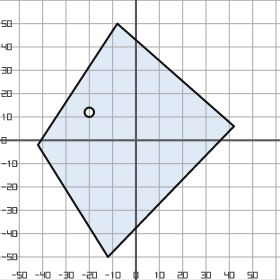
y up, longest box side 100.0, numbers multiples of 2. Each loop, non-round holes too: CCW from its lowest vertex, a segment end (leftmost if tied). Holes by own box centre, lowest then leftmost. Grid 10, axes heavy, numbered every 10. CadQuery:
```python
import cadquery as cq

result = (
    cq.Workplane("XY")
    .moveTo(-12.0, -50.0)
    .lineTo(42.0, 6.0)
    .lineTo(-8.0, 50.0)
    .lineTo(-42.0, -2.0)
    .close()
    .moveTo(-20.0, 12.0)
    .circle(2.0)
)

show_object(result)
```